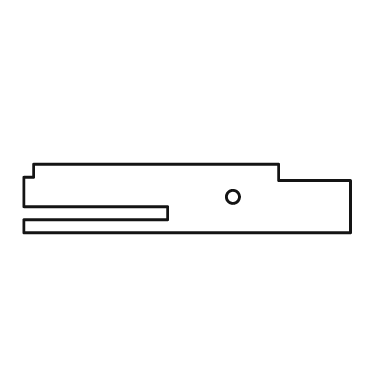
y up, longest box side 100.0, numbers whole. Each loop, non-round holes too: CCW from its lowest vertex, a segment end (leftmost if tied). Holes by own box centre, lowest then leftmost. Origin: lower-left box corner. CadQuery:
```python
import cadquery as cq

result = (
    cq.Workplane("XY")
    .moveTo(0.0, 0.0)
    .lineTo(100.0, 0.0)
    .lineTo(100.0, 16.0)
    .lineTo(78.0, 16.0)
    .lineTo(78.0, 21.0)
    .lineTo(3.0, 21.0)
    .lineTo(3.0, 17.0)
    .lineTo(0.0, 17.0)
    .lineTo(0.0, 8.0)
    .lineTo(44.0, 8.0)
    .lineTo(44.0, 4.0)
    .lineTo(0.0, 4.0)
    .close()
    .moveTo(64.0, 11.0)
    .circle(2.0)
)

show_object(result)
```